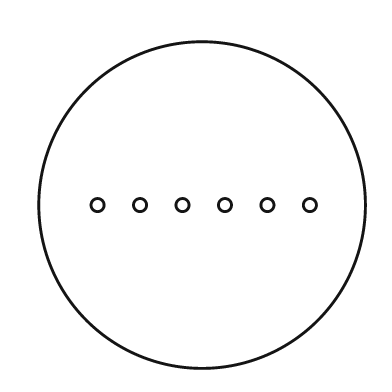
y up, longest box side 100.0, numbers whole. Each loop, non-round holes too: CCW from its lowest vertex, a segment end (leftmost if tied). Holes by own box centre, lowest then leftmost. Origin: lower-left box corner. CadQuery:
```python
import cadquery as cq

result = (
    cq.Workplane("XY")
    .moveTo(50.0, 50.0)
    .circle(50.0)
    .moveTo(18.0, 50.0)
    .circle(2.0)
    .moveTo(31.0, 50.0)
    .circle(2.0)
    .moveTo(44.0, 50.0)
    .circle(2.0)
    .moveTo(57.0, 50.0)
    .circle(2.0)
    .moveTo(70.0, 50.0)
    .circle(2.0)
    .moveTo(83.0, 50.0)
    .circle(2.0)
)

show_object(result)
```